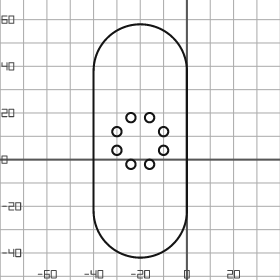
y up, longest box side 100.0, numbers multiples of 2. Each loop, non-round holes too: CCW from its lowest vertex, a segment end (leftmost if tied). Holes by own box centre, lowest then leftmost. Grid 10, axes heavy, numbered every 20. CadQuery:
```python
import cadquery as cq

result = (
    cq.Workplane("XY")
    .moveTo(-40.0, -22.0)
    .threePointArc((-20.0, -42.0), (0.0, -22.0))
    .lineTo(0.0, 38.0)
    .threePointArc((-20.0, 58.0), (-40.0, 38.0))
    .close()
    .moveTo(-24.0, -2.0)
    .circle(2.0)
    .moveTo(-16.0, -2.0)
    .circle(2.0)
    .moveTo(-30.0, 4.0)
    .circle(2.0)
    .moveTo(-10.0, 4.0)
    .circle(2.0)
    .moveTo(-30.0, 12.0)
    .circle(2.0)
    .moveTo(-10.0, 12.0)
    .circle(2.0)
    .moveTo(-24.0, 18.0)
    .circle(2.0)
    .moveTo(-16.0, 18.0)
    .circle(2.0)
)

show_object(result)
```